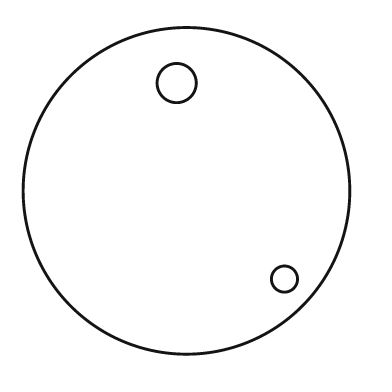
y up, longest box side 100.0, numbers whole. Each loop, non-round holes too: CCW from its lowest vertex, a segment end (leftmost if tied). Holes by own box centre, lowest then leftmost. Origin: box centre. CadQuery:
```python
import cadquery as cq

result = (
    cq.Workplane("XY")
    .moveTo(0.0, 0.0)
    .circle(50.0)
    .moveTo(30.0, -27.0)
    .circle(4.0)
    .moveTo(-3.0, 33.0)
    .circle(6.0)
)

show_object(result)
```